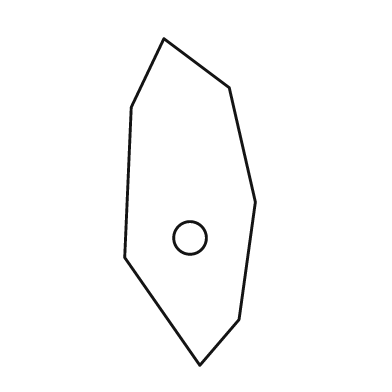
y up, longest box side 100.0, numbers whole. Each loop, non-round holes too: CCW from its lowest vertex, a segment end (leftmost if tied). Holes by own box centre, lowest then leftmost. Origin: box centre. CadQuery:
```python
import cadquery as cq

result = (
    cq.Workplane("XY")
    .moveTo(3.0, -50.0)
    .lineTo(15.0, -36.0)
    .lineTo(20.0, 0.0)
    .lineTo(12.0, 35.0)
    .lineTo(-8.0, 50.0)
    .lineTo(-18.0, 29.0)
    .lineTo(-20.0, -17.0)
    .close()
    .moveTo(0.0, -11.0)
    .circle(5.0)
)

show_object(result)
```